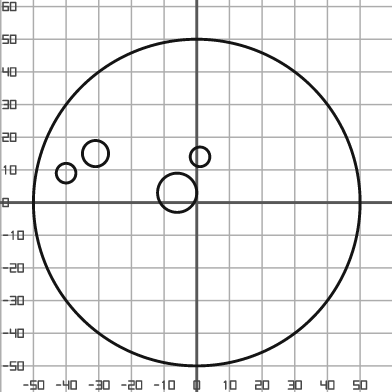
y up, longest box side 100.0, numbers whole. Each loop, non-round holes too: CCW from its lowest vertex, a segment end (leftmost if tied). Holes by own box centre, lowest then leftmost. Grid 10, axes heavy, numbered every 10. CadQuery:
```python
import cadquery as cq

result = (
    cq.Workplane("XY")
    .moveTo(0.0, 0.0)
    .circle(50.0)
    .moveTo(-6.0, 3.0)
    .circle(6.0)
    .moveTo(-40.0, 9.0)
    .circle(3.0)
    .moveTo(1.0, 14.0)
    .circle(3.0)
    .moveTo(-31.0, 15.0)
    .circle(4.0)
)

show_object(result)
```